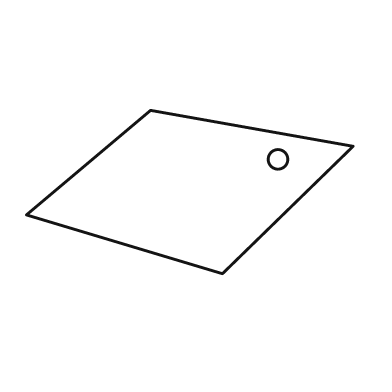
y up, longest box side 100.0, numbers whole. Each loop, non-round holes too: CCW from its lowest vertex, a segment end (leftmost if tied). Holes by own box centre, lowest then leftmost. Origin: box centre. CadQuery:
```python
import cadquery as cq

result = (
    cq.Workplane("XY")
    .moveTo(10.0, -25.0)
    .lineTo(50.0, 14.0)
    .lineTo(-12.0, 25.0)
    .lineTo(-50.0, -7.0)
    .close()
    .moveTo(27.0, 10.0)
    .circle(3.0)
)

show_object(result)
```